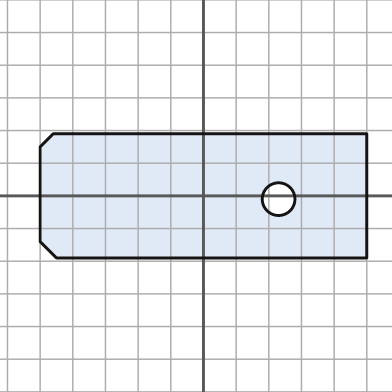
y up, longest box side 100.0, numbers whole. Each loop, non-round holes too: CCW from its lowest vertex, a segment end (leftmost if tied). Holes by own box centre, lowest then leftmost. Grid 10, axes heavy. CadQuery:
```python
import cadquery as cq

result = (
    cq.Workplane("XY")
    .moveTo(-45.0, -19.0)
    .lineTo(50.0, -19.0)
    .lineTo(50.0, 19.0)
    .lineTo(-46.0, 19.0)
    .lineTo(-50.0, 15.0)
    .lineTo(-50.0, -14.0)
    .close()
    .moveTo(23.0, -1.0)
    .circle(5.0)
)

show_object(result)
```